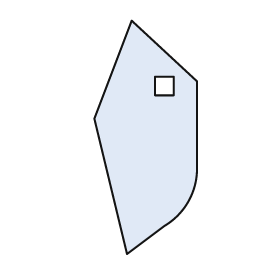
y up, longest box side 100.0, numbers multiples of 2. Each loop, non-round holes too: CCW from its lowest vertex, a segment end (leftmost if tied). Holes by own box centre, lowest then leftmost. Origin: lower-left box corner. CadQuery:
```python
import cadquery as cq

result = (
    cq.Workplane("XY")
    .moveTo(14.0, 0.0)
    .lineTo(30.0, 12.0)
    .threePointArc((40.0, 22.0), (44.0, 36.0))
    .lineTo(44.0, 74.0)
    .lineTo(16.0, 100.0)
    .lineTo(0.0, 58.0)
    .close()
    .moveTo(26.0, 68.0)
    .lineTo(34.0, 68.0)
    .lineTo(34.0, 76.0)
    .lineTo(26.0, 76.0)
    .close()
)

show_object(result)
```